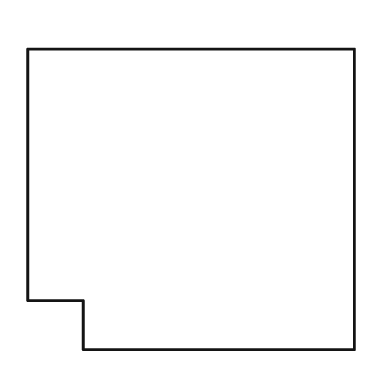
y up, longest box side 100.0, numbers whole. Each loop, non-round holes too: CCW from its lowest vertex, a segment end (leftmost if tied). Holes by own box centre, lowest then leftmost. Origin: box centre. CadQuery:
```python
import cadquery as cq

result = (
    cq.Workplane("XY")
    .moveTo(-33.0, -46.0)
    .lineTo(50.0, -46.0)
    .lineTo(50.0, 46.0)
    .lineTo(-50.0, 46.0)
    .lineTo(-50.0, -31.0)
    .lineTo(-33.0, -31.0)
    .close()
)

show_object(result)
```